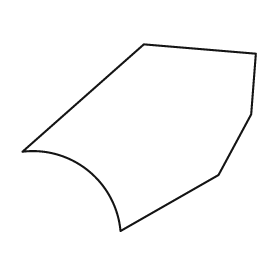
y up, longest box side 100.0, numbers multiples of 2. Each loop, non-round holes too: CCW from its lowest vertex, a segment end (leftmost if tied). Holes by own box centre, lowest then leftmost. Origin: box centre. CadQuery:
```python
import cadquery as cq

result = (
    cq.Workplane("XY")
    .moveTo(-8.0, -40.0)
    .lineTo(34.0, -16.0)
    .lineTo(48.0, 10.0)
    .lineTo(50.0, 36.0)
    .lineTo(2.0, 40.0)
    .lineTo(-50.0, -6.0)
    .threePointArc((-22.0, -14.0), (-8.0, -40.0))
    .close()
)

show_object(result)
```